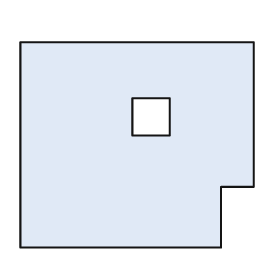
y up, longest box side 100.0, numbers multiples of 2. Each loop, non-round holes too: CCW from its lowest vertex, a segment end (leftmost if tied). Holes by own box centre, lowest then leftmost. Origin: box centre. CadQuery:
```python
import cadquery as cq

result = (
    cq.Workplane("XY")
    .moveTo(-50.0, -44.0)
    .lineTo(36.0, -44.0)
    .lineTo(36.0, -18.0)
    .lineTo(50.0, -18.0)
    .lineTo(50.0, 44.0)
    .lineTo(-50.0, 44.0)
    .close()
    .moveTo(-2.0, 4.0)
    .lineTo(14.0, 4.0)
    .lineTo(14.0, 20.0)
    .lineTo(-2.0, 20.0)
    .close()
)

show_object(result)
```